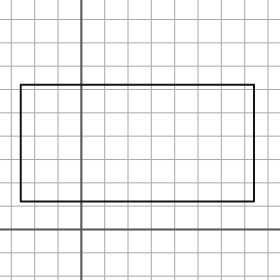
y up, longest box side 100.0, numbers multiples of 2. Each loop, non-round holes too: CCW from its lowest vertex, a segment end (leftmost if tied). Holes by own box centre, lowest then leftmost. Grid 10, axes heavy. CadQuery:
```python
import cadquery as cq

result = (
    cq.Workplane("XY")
    .moveTo(-26.0, 12.0)
    .lineTo(74.0, 12.0)
    .lineTo(74.0, 62.0)
    .lineTo(-26.0, 62.0)
    .close()
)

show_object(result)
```